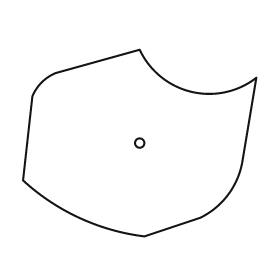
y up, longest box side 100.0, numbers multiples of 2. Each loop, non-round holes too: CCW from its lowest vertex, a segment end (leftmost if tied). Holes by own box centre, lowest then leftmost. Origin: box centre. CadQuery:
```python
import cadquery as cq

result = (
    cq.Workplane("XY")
    .moveTo(2.0, -40.0)
    .lineTo(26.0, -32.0)
    .threePointArc((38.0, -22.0), (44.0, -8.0))
    .lineTo(50.0, 28.0)
    .threePointArc((22.0, 22.0), (0.0, 40.0))
    .lineTo(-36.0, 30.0)
    .threePointArc((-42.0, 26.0), (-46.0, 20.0))
    .lineTo(-50.0, -16.0)
    .threePointArc((-26.0, -32.0), (2.0, -40.0))
    .close()
    .moveTo(0.0, 0.0)
    .circle(2.0)
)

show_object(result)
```